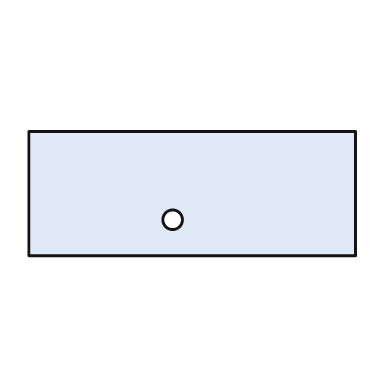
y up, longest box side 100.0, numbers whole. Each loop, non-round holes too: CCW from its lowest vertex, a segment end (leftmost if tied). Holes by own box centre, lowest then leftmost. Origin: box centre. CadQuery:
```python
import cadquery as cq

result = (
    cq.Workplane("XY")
    .moveTo(-50.0, -19.0)
    .lineTo(50.0, -19.0)
    .lineTo(50.0, 19.0)
    .lineTo(-50.0, 19.0)
    .close()
    .moveTo(-6.0, -8.0)
    .circle(3.0)
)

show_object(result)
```